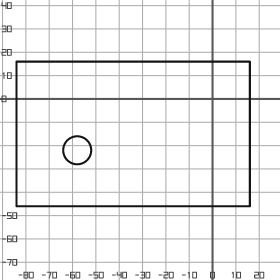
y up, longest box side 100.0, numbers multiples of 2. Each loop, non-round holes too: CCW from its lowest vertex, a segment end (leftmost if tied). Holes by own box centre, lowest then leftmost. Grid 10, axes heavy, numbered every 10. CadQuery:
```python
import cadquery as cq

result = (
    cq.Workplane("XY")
    .moveTo(-84.0, -46.0)
    .lineTo(16.0, -46.0)
    .lineTo(16.0, 16.0)
    .lineTo(-84.0, 16.0)
    .close()
    .moveTo(-58.0, -22.0)
    .circle(6.0)
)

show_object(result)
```